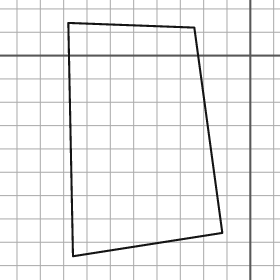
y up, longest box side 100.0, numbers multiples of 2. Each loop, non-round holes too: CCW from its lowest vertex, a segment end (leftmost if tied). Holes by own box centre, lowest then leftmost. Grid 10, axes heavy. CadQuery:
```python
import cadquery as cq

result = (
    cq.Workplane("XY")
    .moveTo(-76.0, -86.0)
    .lineTo(-12.0, -76.0)
    .lineTo(-24.0, 12.0)
    .lineTo(-78.0, 14.0)
    .close()
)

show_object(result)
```